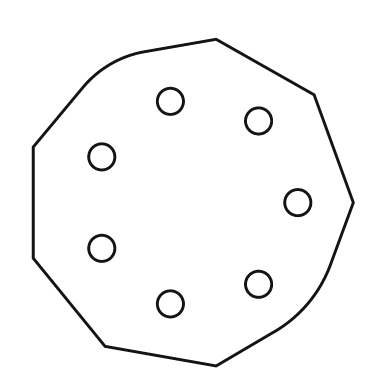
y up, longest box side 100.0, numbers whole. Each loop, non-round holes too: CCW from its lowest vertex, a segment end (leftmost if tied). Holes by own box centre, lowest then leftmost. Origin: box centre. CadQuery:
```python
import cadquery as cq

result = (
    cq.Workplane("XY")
    .moveTo(7.0, -50.0)
    .lineTo(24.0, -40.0)
    .threePointArc((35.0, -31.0), (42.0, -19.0))
    .lineTo(49.0, 0.0)
    .lineTo(37.0, 33.0)
    .lineTo(7.0, 50.0)
    .lineTo(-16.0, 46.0)
    .threePointArc((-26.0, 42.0), (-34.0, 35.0))
    .lineTo(-49.0, 17.0)
    .lineTo(-49.0, -17.0)
    .lineTo(-27.0, -44.0)
    .close()
    .moveTo(-7.0, -31.0)
    .circle(4.0)
    .moveTo(20.0, -25.0)
    .circle(4.0)
    .moveTo(-28.0, -14.0)
    .circle(4.0)
    .moveTo(32.0, 0.0)
    .circle(4.0)
    .moveTo(-28.0, 14.0)
    .circle(4.0)
    .moveTo(20.0, 25.0)
    .circle(4.0)
    .moveTo(-7.0, 31.0)
    .circle(4.0)
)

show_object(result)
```